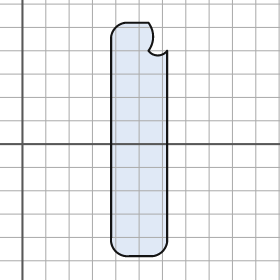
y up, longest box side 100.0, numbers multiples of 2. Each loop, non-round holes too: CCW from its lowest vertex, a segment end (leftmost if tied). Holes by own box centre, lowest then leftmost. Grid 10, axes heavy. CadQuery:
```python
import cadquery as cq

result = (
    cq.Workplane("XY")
    .moveTo(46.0, -48.0)
    .lineTo(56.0, -48.0)
    .threePointArc((60.0, -46.0), (62.0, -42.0))
    .lineTo(62.0, 40.0)
    .threePointArc((58.0, 38.0), (54.0, 40.0))
    .threePointArc((56.0, 46.0), (54.0, 52.0))
    .lineTo(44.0, 52.0)
    .threePointArc((40.0, 50.0), (38.0, 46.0))
    .lineTo(38.0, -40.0)
    .threePointArc((40.0, -46.0), (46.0, -48.0))
    .close()
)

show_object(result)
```